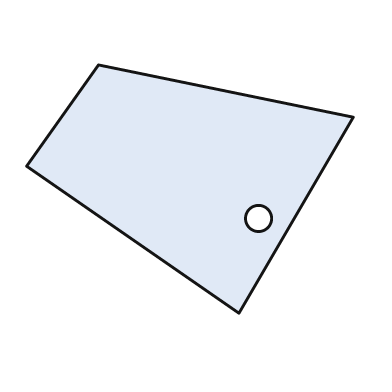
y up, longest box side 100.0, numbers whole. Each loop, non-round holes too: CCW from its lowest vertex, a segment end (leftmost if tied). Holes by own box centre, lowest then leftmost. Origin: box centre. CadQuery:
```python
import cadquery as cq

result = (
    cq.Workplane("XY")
    .moveTo(15.0, -38.0)
    .lineTo(50.0, 22.0)
    .lineTo(-28.0, 38.0)
    .lineTo(-50.0, 7.0)
    .close()
    .moveTo(21.0, -9.0)
    .circle(4.0)
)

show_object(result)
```